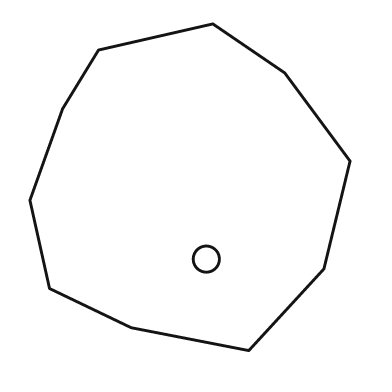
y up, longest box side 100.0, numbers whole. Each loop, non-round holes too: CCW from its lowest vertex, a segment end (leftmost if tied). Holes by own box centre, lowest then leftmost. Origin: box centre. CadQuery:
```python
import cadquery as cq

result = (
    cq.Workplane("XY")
    .moveTo(18.0, -50.0)
    .lineTo(41.0, -25.0)
    .lineTo(49.0, 8.0)
    .lineTo(29.0, 35.0)
    .lineTo(7.0, 50.0)
    .lineTo(-28.0, 42.0)
    .lineTo(-39.0, 24.0)
    .lineTo(-49.0, -4.0)
    .lineTo(-43.0, -31.0)
    .lineTo(-18.0, -43.0)
    .close()
    .moveTo(5.0, -22.0)
    .circle(4.0)
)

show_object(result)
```